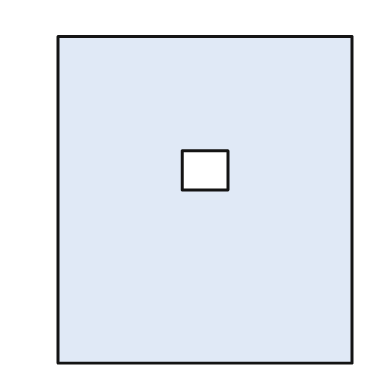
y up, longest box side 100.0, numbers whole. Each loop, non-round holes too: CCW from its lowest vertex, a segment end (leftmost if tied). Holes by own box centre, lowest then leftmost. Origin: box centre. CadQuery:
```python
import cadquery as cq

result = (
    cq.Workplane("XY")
    .moveTo(-45.0, -50.0)
    .lineTo(45.0, -50.0)
    .lineTo(45.0, 50.0)
    .lineTo(-45.0, 50.0)
    .close()
    .moveTo(-7.0, 3.0)
    .lineTo(7.0, 3.0)
    .lineTo(7.0, 15.0)
    .lineTo(-7.0, 15.0)
    .close()
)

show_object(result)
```